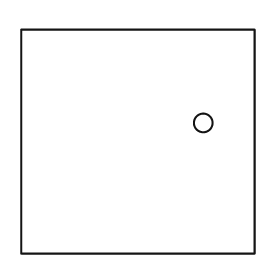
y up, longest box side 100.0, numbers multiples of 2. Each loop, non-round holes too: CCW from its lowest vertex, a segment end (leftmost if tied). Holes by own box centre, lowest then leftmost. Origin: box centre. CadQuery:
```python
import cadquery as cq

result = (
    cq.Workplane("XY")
    .moveTo(-50.0, -48.0)
    .lineTo(50.0, -48.0)
    .lineTo(50.0, 48.0)
    .lineTo(-50.0, 48.0)
    .close()
    .moveTo(28.0, 8.0)
    .circle(4.0)
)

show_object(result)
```